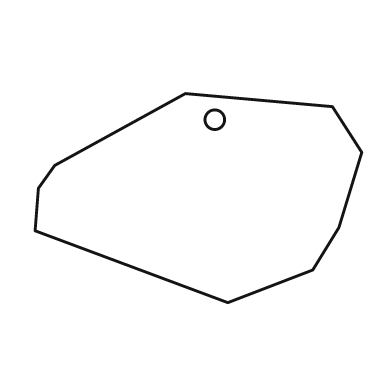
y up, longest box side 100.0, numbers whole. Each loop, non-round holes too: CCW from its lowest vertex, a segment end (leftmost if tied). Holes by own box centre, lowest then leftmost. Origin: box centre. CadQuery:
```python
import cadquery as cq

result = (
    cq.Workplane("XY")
    .moveTo(9.0, -32.0)
    .lineTo(35.0, -22.0)
    .lineTo(43.0, -9.0)
    .lineTo(50.0, 14.0)
    .lineTo(41.0, 28.0)
    .lineTo(-4.0, 32.0)
    .lineTo(-44.0, 10.0)
    .lineTo(-49.0, 3.0)
    .lineTo(-50.0, -10.0)
    .close()
    .moveTo(5.0, 24.0)
    .circle(3.0)
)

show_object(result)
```